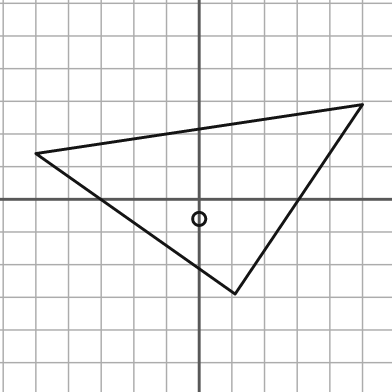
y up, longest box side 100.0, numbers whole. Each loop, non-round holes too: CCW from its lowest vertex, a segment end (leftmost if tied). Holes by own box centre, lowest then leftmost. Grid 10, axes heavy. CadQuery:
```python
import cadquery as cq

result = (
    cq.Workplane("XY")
    .moveTo(11.0, -29.0)
    .lineTo(50.0, 29.0)
    .lineTo(-50.0, 14.0)
    .close()
    .moveTo(0.0, -6.0)
    .circle(2.0)
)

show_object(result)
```